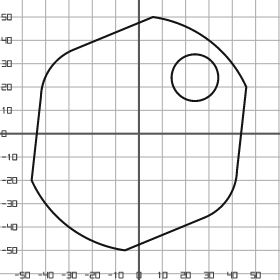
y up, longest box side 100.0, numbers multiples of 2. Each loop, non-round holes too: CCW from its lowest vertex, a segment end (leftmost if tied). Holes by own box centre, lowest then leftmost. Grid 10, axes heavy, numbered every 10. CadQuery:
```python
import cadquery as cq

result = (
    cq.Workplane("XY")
    .moveTo(-6.0, -50.0)
    .lineTo(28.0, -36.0)
    .threePointArc((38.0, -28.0), (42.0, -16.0))
    .lineTo(46.0, 20.0)
    .threePointArc((30.0, 40.0), (6.0, 50.0))
    .lineTo(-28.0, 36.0)
    .threePointArc((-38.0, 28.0), (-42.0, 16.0))
    .lineTo(-46.0, -20.0)
    .threePointArc((-30.0, -40.0), (-6.0, -50.0))
    .close()
    .moveTo(24.0, 24.0)
    .circle(10.0)
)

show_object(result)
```